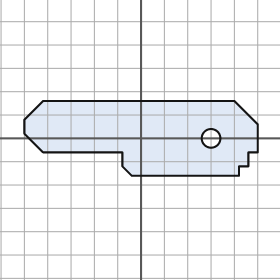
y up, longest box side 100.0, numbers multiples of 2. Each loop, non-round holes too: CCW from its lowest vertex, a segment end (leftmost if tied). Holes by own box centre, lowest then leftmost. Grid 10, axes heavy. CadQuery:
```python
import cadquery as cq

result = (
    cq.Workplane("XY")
    .moveTo(-4.0, -16.0)
    .lineTo(42.0, -16.0)
    .lineTo(42.0, -12.0)
    .lineTo(46.0, -12.0)
    .lineTo(46.0, -6.0)
    .lineTo(50.0, -6.0)
    .lineTo(50.0, 6.0)
    .lineTo(40.0, 16.0)
    .lineTo(-42.0, 16.0)
    .lineTo(-50.0, 8.0)
    .lineTo(-50.0, 2.0)
    .lineTo(-42.0, -6.0)
    .lineTo(-8.0, -6.0)
    .lineTo(-8.0, -12.0)
    .close()
    .moveTo(30.0, 0.0)
    .circle(4.0)
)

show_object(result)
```